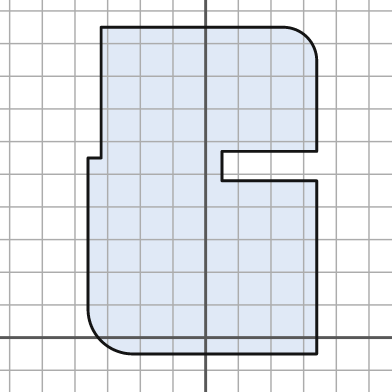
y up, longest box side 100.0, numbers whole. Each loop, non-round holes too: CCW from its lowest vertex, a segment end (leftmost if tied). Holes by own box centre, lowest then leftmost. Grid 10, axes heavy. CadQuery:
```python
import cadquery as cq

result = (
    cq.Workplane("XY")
    .moveTo(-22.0, -5.0)
    .lineTo(34.0, -5.0)
    .lineTo(34.0, 48.0)
    .lineTo(5.0, 48.0)
    .lineTo(5.0, 57.0)
    .lineTo(34.0, 57.0)
    .lineTo(34.0, 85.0)
    .threePointArc((31.0, 92.0), (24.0, 95.0))
    .lineTo(-32.0, 95.0)
    .lineTo(-32.0, 55.0)
    .lineTo(-36.0, 55.0)
    .lineTo(-36.0, 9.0)
    .threePointArc((-32.0, -1.0), (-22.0, -5.0))
    .close()
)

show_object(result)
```